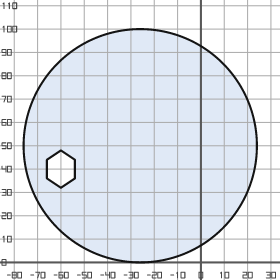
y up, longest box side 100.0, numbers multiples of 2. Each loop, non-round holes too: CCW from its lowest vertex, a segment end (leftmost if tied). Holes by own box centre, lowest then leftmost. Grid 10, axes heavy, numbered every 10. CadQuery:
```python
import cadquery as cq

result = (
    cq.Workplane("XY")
    .moveTo(-26.0, 50.0)
    .circle(50.0)
    .moveTo(-60.0, 32.0)
    .lineTo(-54.0, 36.0)
    .lineTo(-54.0, 44.0)
    .lineTo(-60.0, 48.0)
    .lineTo(-66.0, 44.0)
    .lineTo(-66.0, 36.0)
    .close()
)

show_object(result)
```